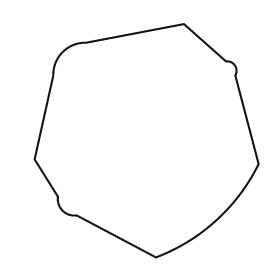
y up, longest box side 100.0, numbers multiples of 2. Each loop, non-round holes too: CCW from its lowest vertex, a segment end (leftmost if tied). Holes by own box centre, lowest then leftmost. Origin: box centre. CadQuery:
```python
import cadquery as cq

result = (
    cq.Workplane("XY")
    .moveTo(4.0, -50.0)
    .threePointArc((30.0, -34.0), (48.0, -10.0))
    .lineTo(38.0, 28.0)
    .threePointArc((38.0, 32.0), (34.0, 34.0))
    .lineTo(16.0, 50.0)
    .lineTo(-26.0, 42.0)
    .threePointArc((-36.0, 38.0), (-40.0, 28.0))
    .lineTo(-48.0, -8.0)
    .lineTo(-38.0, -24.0)
    .threePointArc((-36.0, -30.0), (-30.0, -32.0))
    .close()
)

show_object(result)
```